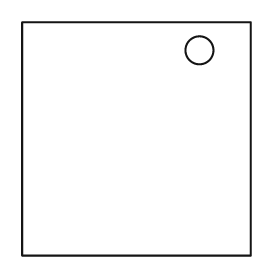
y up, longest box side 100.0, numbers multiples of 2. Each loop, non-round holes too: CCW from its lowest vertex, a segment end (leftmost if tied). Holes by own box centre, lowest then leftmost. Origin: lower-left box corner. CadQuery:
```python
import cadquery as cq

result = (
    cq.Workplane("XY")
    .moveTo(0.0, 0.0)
    .lineTo(98.0, 0.0)
    .lineTo(98.0, 100.0)
    .lineTo(0.0, 100.0)
    .close()
    .moveTo(76.0, 88.0)
    .circle(6.0)
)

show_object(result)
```